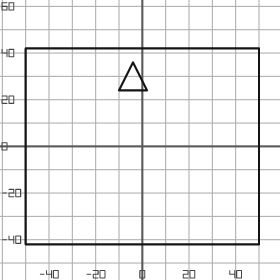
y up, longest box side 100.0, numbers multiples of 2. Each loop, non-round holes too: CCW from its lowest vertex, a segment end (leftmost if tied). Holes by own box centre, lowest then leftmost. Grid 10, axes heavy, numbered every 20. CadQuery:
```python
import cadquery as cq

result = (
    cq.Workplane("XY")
    .moveTo(-50.0, -42.0)
    .lineTo(50.0, -42.0)
    .lineTo(50.0, 42.0)
    .lineTo(-50.0, 42.0)
    .close()
    .moveTo(-10.0, 24.0)
    .lineTo(2.0, 24.0)
    .lineTo(-4.0, 36.0)
    .close()
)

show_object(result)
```